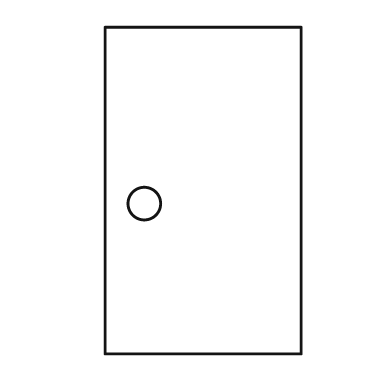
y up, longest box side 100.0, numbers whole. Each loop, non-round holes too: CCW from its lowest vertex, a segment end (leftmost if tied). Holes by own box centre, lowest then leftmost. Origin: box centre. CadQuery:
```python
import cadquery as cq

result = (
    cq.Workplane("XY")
    .moveTo(-30.0, -50.0)
    .lineTo(30.0, -50.0)
    .lineTo(30.0, 50.0)
    .lineTo(-30.0, 50.0)
    .close()
    .moveTo(-18.0, -4.0)
    .circle(5.0)
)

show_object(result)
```